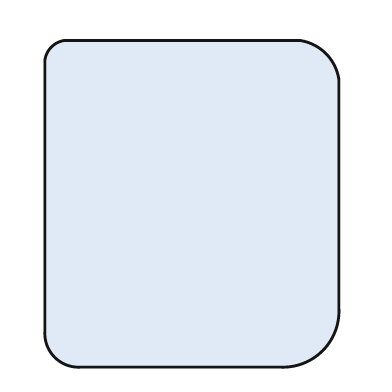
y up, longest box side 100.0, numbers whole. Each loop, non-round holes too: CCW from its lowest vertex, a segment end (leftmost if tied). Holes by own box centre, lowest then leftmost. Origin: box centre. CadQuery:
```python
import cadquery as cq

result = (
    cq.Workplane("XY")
    .moveTo(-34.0, -50.0)
    .lineTo(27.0, -50.0)
    .threePointArc((40.0, -45.0), (45.0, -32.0))
    .lineTo(45.0, 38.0)
    .threePointArc((41.0, 46.0), (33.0, 50.0))
    .lineTo(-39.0, 50.0)
    .threePointArc((-43.0, 48.0), (-45.0, 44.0))
    .lineTo(-45.0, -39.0)
    .threePointArc((-42.0, -47.0), (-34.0, -50.0))
    .close()
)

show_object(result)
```